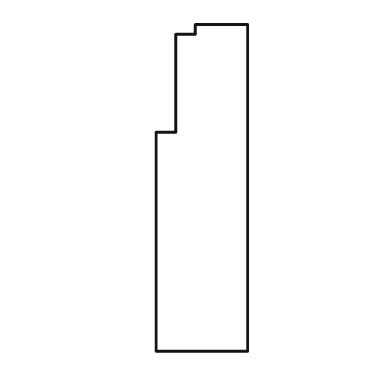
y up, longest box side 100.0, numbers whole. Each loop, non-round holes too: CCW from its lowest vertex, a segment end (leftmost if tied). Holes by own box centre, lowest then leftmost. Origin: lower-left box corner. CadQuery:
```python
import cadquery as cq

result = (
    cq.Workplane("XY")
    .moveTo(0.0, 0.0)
    .lineTo(28.0, 0.0)
    .lineTo(28.0, 100.0)
    .lineTo(12.0, 100.0)
    .lineTo(12.0, 97.0)
    .lineTo(6.0, 97.0)
    .lineTo(6.0, 67.0)
    .lineTo(0.0, 67.0)
    .close()
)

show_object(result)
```